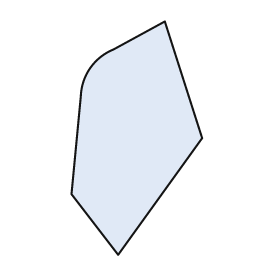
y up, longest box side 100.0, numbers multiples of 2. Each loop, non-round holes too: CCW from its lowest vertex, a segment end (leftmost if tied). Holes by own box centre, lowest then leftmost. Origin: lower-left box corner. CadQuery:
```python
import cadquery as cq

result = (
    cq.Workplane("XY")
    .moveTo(20.0, 0.0)
    .lineTo(56.0, 50.0)
    .lineTo(40.0, 100.0)
    .lineTo(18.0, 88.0)
    .threePointArc((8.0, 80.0), (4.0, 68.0))
    .lineTo(0.0, 26.0)
    .close()
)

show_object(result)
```